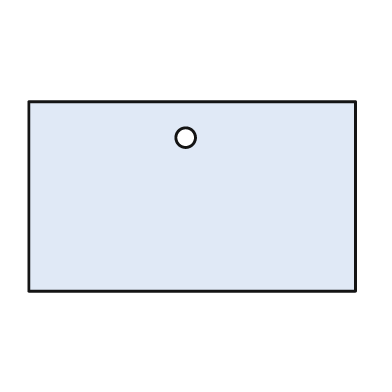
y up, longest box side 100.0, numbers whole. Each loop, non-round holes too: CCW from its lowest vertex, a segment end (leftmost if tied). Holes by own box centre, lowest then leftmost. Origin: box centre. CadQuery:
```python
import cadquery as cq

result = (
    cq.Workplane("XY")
    .moveTo(-50.0, -29.0)
    .lineTo(50.0, -29.0)
    .lineTo(50.0, 29.0)
    .lineTo(-50.0, 29.0)
    .close()
    .moveTo(-2.0, 18.0)
    .circle(3.0)
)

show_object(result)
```